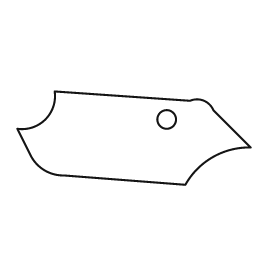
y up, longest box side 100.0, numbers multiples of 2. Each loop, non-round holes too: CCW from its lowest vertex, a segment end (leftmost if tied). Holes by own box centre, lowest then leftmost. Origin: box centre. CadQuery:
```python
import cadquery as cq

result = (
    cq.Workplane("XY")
    .moveTo(22.0, -20.0)
    .threePointArc((34.0, -8.0), (50.0, -4.0))
    .lineTo(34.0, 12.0)
    .threePointArc((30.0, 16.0), (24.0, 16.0))
    .lineTo(-34.0, 20.0)
    .threePointArc((-38.0, 8.0), (-50.0, 4.0))
    .lineTo(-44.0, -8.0)
    .threePointArc((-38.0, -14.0), (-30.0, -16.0))
    .close()
    .moveTo(14.0, 8.0)
    .circle(4.0)
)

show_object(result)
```